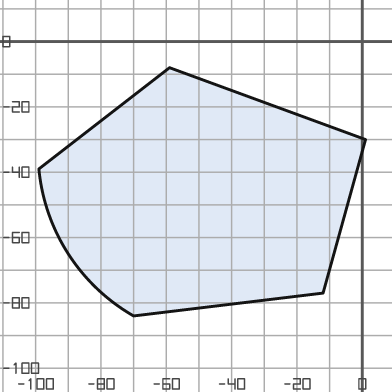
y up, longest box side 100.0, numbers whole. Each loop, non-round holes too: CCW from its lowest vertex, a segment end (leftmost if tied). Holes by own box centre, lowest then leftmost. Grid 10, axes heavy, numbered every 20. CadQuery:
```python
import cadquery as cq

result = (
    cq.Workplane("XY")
    .moveTo(-70.0, -84.0)
    .lineTo(-12.0, -77.0)
    .lineTo(1.0, -30.0)
    .lineTo(-59.0, -8.0)
    .lineTo(-99.0, -39.0)
    .threePointArc((-90.0, -65.0), (-70.0, -84.0))
    .close()
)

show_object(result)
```